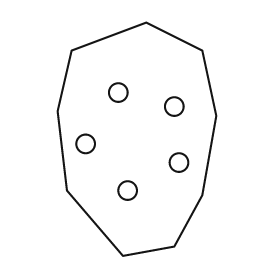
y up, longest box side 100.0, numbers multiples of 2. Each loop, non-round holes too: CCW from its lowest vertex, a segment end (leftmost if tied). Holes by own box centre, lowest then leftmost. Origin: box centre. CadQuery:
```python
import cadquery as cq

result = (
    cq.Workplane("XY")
    .moveTo(-6.0, -50.0)
    .lineTo(16.0, -46.0)
    .lineTo(28.0, -24.0)
    .lineTo(34.0, 10.0)
    .lineTo(28.0, 38.0)
    .lineTo(4.0, 50.0)
    .lineTo(-28.0, 38.0)
    .lineTo(-34.0, 12.0)
    .lineTo(-30.0, -22.0)
    .close()
    .moveTo(-4.0, -22.0)
    .circle(4.0)
    .moveTo(18.0, -10.0)
    .circle(4.0)
    .moveTo(-22.0, -2.0)
    .circle(4.0)
    .moveTo(16.0, 14.0)
    .circle(4.0)
    .moveTo(-8.0, 20.0)
    .circle(4.0)
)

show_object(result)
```